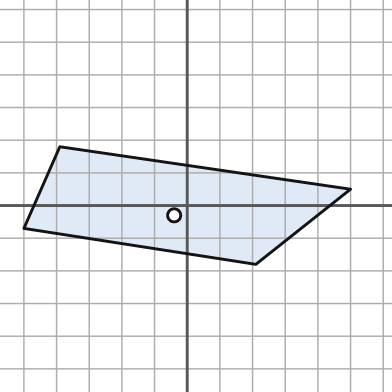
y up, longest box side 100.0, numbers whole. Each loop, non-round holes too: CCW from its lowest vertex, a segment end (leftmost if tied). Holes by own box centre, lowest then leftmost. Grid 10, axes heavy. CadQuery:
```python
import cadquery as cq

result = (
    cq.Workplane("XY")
    .moveTo(21.0, -18.0)
    .lineTo(50.0, 5.0)
    .lineTo(-39.0, 18.0)
    .lineTo(-50.0, -7.0)
    .close()
    .moveTo(-4.0, -3.0)
    .circle(2.0)
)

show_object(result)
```